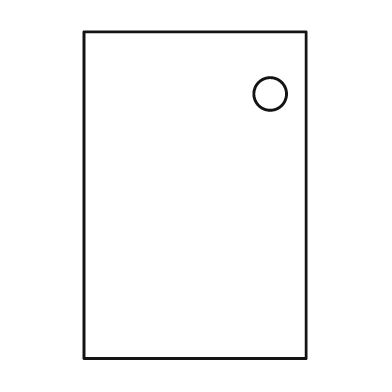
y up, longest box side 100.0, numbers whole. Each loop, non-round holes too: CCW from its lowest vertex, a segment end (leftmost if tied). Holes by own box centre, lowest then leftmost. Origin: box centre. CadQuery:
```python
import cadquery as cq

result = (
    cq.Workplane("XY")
    .moveTo(-34.0, -50.0)
    .lineTo(34.0, -50.0)
    .lineTo(34.0, 50.0)
    .lineTo(-34.0, 50.0)
    .close()
    .moveTo(23.0, 31.0)
    .circle(5.0)
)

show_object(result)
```